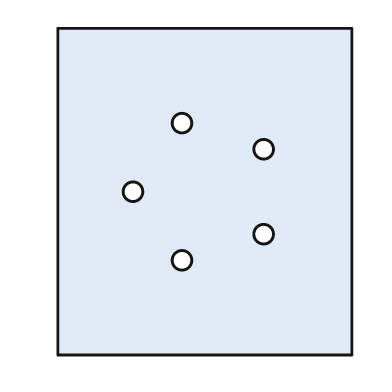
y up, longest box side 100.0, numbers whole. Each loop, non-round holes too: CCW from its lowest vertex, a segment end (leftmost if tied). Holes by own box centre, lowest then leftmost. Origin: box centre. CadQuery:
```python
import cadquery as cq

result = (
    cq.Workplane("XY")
    .moveTo(-45.0, -50.0)
    .lineTo(45.0, -50.0)
    .lineTo(45.0, 50.0)
    .lineTo(-45.0, 50.0)
    .close()
    .moveTo(-7.0, -21.0)
    .circle(3.0)
    .moveTo(18.0, -13.0)
    .circle(3.0)
    .moveTo(-22.0, 0.0)
    .circle(3.0)
    .moveTo(18.0, 13.0)
    .circle(3.0)
    .moveTo(-7.0, 21.0)
    .circle(3.0)
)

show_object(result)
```